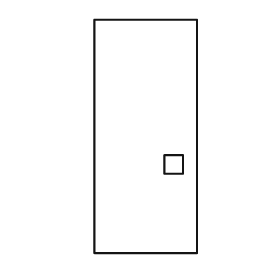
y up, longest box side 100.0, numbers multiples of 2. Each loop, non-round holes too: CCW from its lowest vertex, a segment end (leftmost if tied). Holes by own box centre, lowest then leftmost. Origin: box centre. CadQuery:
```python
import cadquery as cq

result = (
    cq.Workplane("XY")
    .moveTo(-22.0, -50.0)
    .lineTo(22.0, -50.0)
    .lineTo(22.0, 50.0)
    .lineTo(-22.0, 50.0)
    .close()
    .moveTo(8.0, -16.0)
    .lineTo(16.0, -16.0)
    .lineTo(16.0, -8.0)
    .lineTo(8.0, -8.0)
    .close()
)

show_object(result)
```